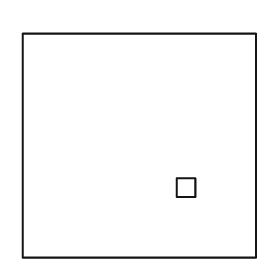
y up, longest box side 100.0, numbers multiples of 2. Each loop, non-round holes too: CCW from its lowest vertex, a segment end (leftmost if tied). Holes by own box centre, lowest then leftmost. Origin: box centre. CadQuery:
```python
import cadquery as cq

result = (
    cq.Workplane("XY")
    .moveTo(-50.0, -48.0)
    .lineTo(50.0, -48.0)
    .lineTo(50.0, 48.0)
    .lineTo(-50.0, 48.0)
    .close()
    .moveTo(16.0, -22.0)
    .lineTo(24.0, -22.0)
    .lineTo(24.0, -14.0)
    .lineTo(16.0, -14.0)
    .close()
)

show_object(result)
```